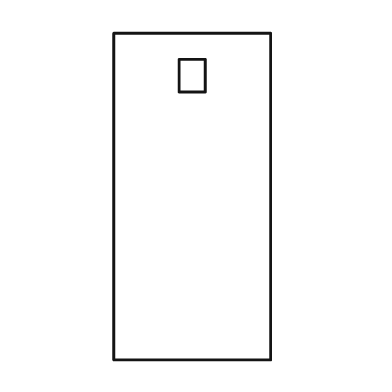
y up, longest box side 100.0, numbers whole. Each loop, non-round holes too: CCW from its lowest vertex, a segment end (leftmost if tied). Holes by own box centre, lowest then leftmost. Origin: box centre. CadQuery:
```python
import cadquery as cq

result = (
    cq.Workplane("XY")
    .moveTo(-24.0, -50.0)
    .lineTo(24.0, -50.0)
    .lineTo(24.0, 50.0)
    .lineTo(-24.0, 50.0)
    .close()
    .moveTo(-4.0, 32.0)
    .lineTo(4.0, 32.0)
    .lineTo(4.0, 42.0)
    .lineTo(-4.0, 42.0)
    .close()
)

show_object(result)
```